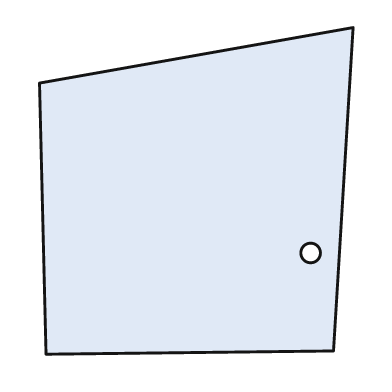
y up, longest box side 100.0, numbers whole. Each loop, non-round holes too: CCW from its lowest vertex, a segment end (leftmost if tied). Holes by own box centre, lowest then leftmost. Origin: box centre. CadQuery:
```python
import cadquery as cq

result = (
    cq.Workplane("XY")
    .moveTo(-46.0, -50.0)
    .lineTo(42.0, -49.0)
    .lineTo(48.0, 50.0)
    .lineTo(-48.0, 33.0)
    .close()
    .moveTo(35.0, -19.0)
    .circle(3.0)
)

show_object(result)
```